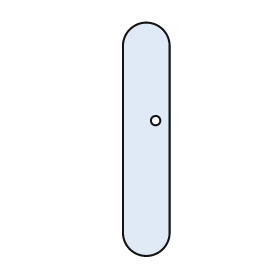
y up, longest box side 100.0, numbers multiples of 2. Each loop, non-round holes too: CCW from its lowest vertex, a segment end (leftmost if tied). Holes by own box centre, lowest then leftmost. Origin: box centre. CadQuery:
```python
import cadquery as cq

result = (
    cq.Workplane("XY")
    .moveTo(-10.0, -40.0)
    .threePointArc((0.0, -50.0), (10.0, -40.0))
    .lineTo(10.0, 40.0)
    .threePointArc((0.0, 50.0), (-10.0, 40.0))
    .close()
    .moveTo(4.0, 8.0)
    .circle(2.0)
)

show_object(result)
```